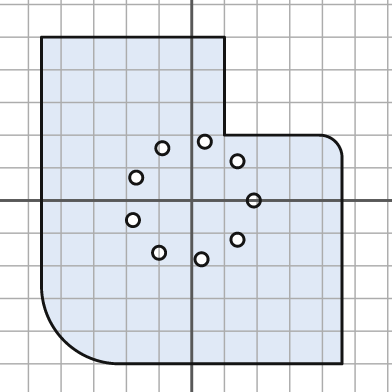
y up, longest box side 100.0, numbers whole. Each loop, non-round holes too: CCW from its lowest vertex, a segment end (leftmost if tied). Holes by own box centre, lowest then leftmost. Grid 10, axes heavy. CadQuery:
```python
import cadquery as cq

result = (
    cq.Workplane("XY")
    .moveTo(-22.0, -50.0)
    .lineTo(46.0, -50.0)
    .lineTo(46.0, 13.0)
    .threePointArc((44.0, 18.0), (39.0, 20.0))
    .lineTo(10.0, 20.0)
    .lineTo(10.0, 50.0)
    .lineTo(-46.0, 50.0)
    .lineTo(-46.0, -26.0)
    .threePointArc((-39.0, -43.0), (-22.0, -50.0))
    .close()
    .moveTo(3.0, -18.0)
    .circle(2.0)
    .moveTo(-10.0, -16.0)
    .circle(2.0)
    .moveTo(14.0, -12.0)
    .circle(2.0)
    .moveTo(-18.0, -6.0)
    .circle(2.0)
    .moveTo(19.0, 0.0)
    .circle(2.0)
    .moveTo(-17.0, 7.0)
    .circle(2.0)
    .moveTo(14.0, 12.0)
    .circle(2.0)
    .moveTo(-9.0, 16.0)
    .circle(2.0)
    .moveTo(4.0, 18.0)
    .circle(2.0)
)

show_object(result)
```